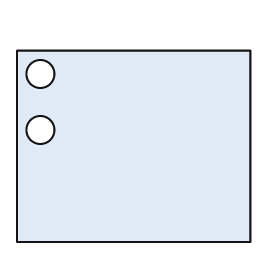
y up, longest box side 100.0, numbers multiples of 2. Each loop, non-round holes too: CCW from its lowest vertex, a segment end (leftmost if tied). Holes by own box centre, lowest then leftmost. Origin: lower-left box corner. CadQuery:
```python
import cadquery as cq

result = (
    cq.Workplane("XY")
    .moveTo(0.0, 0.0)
    .lineTo(100.0, 0.0)
    .lineTo(100.0, 82.0)
    .lineTo(0.0, 82.0)
    .close()
    .moveTo(10.0, 48.0)
    .circle(6.0)
    .moveTo(10.0, 72.0)
    .circle(6.0)
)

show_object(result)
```